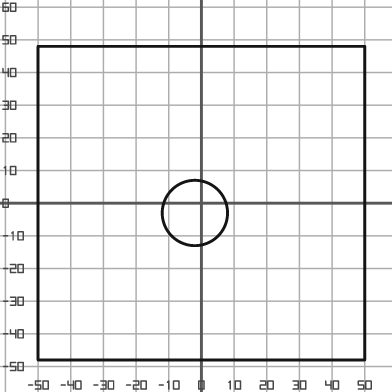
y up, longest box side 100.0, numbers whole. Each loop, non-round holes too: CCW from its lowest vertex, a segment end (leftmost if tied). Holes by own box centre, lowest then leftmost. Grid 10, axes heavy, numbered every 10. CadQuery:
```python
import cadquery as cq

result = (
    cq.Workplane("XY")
    .moveTo(-50.0, -48.0)
    .lineTo(50.0, -48.0)
    .lineTo(50.0, 48.0)
    .lineTo(-50.0, 48.0)
    .close()
    .moveTo(-2.0, -3.0)
    .circle(10.0)
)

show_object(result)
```